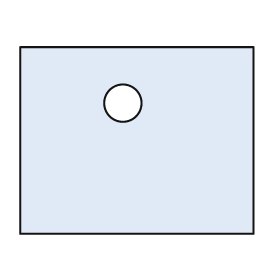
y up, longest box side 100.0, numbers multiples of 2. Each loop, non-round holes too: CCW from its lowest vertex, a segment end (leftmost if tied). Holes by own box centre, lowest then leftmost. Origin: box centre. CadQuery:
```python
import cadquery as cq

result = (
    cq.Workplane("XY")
    .moveTo(-50.0, -40.0)
    .lineTo(50.0, -40.0)
    .lineTo(50.0, 40.0)
    .lineTo(-50.0, 40.0)
    .close()
    .moveTo(-6.0, 16.0)
    .circle(8.0)
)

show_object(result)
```